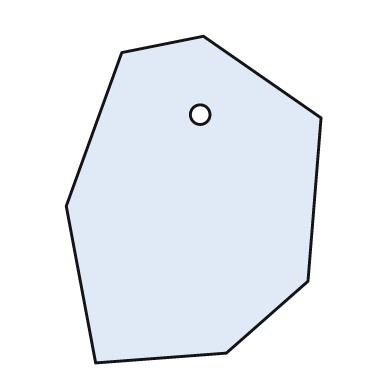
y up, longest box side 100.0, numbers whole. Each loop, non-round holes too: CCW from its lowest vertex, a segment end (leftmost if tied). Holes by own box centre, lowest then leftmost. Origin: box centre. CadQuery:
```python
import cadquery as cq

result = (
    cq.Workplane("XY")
    .moveTo(-30.0, -50.0)
    .lineTo(10.0, -47.0)
    .lineTo(35.0, -25.0)
    .lineTo(39.0, 25.0)
    .lineTo(3.0, 50.0)
    .lineTo(-22.0, 45.0)
    .lineTo(-39.0, -2.0)
    .close()
    .moveTo(2.0, 26.0)
    .circle(3.0)
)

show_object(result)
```